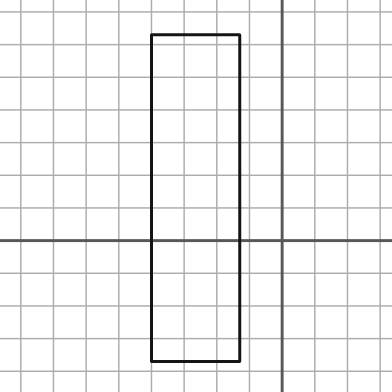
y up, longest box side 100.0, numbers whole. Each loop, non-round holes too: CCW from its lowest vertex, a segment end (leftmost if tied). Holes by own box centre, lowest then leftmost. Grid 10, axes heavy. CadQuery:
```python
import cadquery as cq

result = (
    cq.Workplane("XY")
    .moveTo(-40.0, -37.0)
    .lineTo(-13.0, -37.0)
    .lineTo(-13.0, 63.0)
    .lineTo(-40.0, 63.0)
    .close()
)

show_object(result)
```